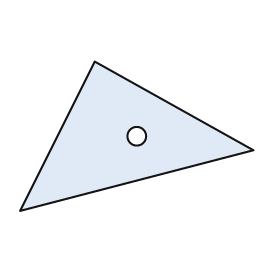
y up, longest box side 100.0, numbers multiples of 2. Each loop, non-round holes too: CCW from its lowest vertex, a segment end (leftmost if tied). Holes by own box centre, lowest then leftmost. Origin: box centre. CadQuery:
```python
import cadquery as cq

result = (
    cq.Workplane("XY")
    .moveTo(-50.0, -32.0)
    .lineTo(50.0, -6.0)
    .lineTo(-18.0, 32.0)
    .close()
    .moveTo(0.0, 0.0)
    .circle(4.0)
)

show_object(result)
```